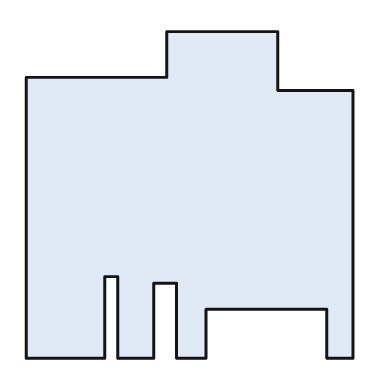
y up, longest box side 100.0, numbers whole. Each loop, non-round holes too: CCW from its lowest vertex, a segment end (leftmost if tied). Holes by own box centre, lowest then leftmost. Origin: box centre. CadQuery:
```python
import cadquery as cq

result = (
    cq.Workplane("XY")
    .moveTo(-50.0, -50.0)
    .lineTo(-26.0, -50.0)
    .lineTo(-26.0, -25.0)
    .lineTo(-22.0, -25.0)
    .lineTo(-22.0, -50.0)
    .lineTo(-11.0, -50.0)
    .lineTo(-11.0, -27.0)
    .lineTo(-4.0, -27.0)
    .lineTo(-4.0, -50.0)
    .lineTo(5.0, -50.0)
    .lineTo(5.0, -35.0)
    .lineTo(42.0, -35.0)
    .lineTo(42.0, -50.0)
    .lineTo(50.0, -50.0)
    .lineTo(50.0, 32.0)
    .lineTo(27.0, 32.0)
    .lineTo(27.0, 50.0)
    .lineTo(-7.0, 50.0)
    .lineTo(-7.0, 36.0)
    .lineTo(-50.0, 36.0)
    .close()
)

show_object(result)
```